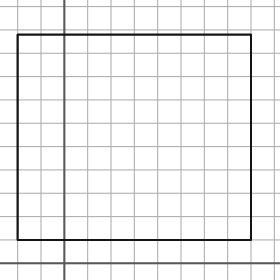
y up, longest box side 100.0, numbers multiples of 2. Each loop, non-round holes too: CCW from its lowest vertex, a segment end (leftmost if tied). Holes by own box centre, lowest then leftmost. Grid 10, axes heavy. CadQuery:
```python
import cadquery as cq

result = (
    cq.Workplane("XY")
    .moveTo(-20.0, 10.0)
    .lineTo(80.0, 10.0)
    .lineTo(80.0, 98.0)
    .lineTo(-20.0, 98.0)
    .close()
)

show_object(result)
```